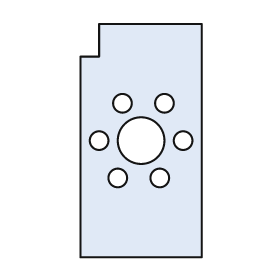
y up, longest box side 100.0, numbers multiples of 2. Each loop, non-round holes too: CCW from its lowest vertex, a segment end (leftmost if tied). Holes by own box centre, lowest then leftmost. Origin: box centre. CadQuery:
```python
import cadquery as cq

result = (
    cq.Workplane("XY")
    .moveTo(-26.0, -50.0)
    .lineTo(26.0, -50.0)
    .lineTo(26.0, 50.0)
    .lineTo(-18.0, 50.0)
    .lineTo(-18.0, 36.0)
    .lineTo(-26.0, 36.0)
    .close()
    .moveTo(-10.0, -16.0)
    .circle(4.0)
    .moveTo(8.0, -16.0)
    .circle(4.0)
    .moveTo(-18.0, 0.0)
    .circle(4.0)
    .moveTo(0.0, 0.0)
    .circle(10.0)
    .moveTo(18.0, 0.0)
    .circle(4.0)
    .moveTo(-8.0, 16.0)
    .circle(4.0)
    .moveTo(10.0, 16.0)
    .circle(4.0)
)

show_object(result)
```